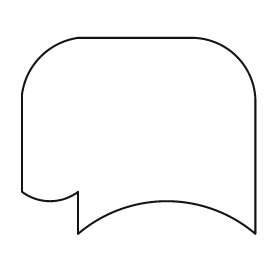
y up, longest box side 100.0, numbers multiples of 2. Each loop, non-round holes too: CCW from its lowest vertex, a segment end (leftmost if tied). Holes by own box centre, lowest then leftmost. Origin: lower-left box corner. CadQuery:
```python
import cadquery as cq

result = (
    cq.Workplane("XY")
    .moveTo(24.0, 0.0)
    .threePointArc((62.0, 14.0), (100.0, 0.0))
    .lineTo(100.0, 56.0)
    .threePointArc((92.0, 76.0), (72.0, 84.0))
    .lineTo(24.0, 84.0)
    .threePointArc((8.0, 76.0), (0.0, 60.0))
    .lineTo(0.0, 18.0)
    .threePointArc((12.0, 14.0), (24.0, 18.0))
    .close()
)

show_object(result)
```